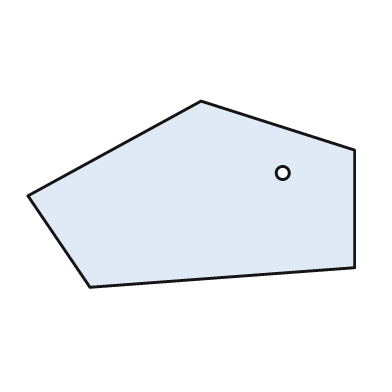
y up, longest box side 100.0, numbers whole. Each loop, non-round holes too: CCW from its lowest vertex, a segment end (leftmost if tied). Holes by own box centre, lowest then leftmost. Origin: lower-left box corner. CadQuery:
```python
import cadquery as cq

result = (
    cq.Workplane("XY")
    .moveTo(19.0, 0.0)
    .lineTo(100.0, 6.0)
    .lineTo(100.0, 42.0)
    .lineTo(53.0, 57.0)
    .lineTo(0.0, 28.0)
    .close()
    .moveTo(78.0, 35.0)
    .circle(2.0)
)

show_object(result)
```